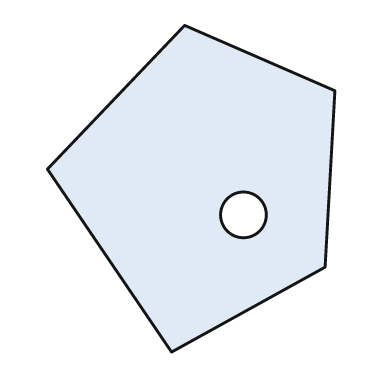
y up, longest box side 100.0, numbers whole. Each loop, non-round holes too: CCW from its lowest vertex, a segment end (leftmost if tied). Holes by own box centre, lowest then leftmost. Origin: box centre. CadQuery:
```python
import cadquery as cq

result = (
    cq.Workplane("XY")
    .moveTo(-6.0, -50.0)
    .lineTo(41.0, -24.0)
    .lineTo(44.0, 30.0)
    .lineTo(-2.0, 50.0)
    .lineTo(-44.0, 6.0)
    .close()
    .moveTo(16.0, -8.0)
    .circle(7.0)
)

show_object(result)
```